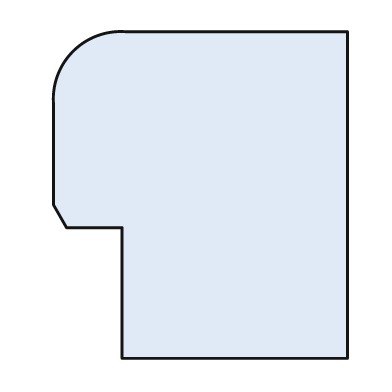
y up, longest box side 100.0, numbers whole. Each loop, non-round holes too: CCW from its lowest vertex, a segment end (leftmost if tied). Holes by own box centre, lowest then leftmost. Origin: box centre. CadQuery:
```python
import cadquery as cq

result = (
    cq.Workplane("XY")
    .moveTo(-24.0, -50.0)
    .lineTo(45.0, -50.0)
    .lineTo(45.0, 50.0)
    .lineTo(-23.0, 50.0)
    .threePointArc((-39.0, 44.0), (-45.0, 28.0))
    .lineTo(-45.0, -3.0)
    .lineTo(-41.0, -10.0)
    .lineTo(-24.0, -10.0)
    .close()
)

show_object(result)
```